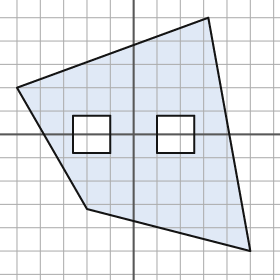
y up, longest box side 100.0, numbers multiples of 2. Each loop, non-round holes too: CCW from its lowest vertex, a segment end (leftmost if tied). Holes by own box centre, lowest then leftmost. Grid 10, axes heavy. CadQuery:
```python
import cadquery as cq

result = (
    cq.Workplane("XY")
    .moveTo(50.0, -50.0)
    .lineTo(32.0, 50.0)
    .lineTo(-50.0, 20.0)
    .lineTo(-20.0, -32.0)
    .close()
    .moveTo(-26.0, -8.0)
    .lineTo(-10.0, -8.0)
    .lineTo(-10.0, 8.0)
    .lineTo(-26.0, 8.0)
    .close()
    .moveTo(10.0, -8.0)
    .lineTo(26.0, -8.0)
    .lineTo(26.0, 8.0)
    .lineTo(10.0, 8.0)
    .close()
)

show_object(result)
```